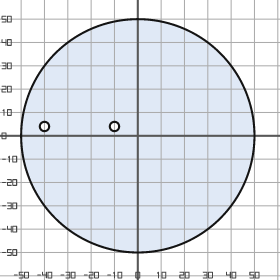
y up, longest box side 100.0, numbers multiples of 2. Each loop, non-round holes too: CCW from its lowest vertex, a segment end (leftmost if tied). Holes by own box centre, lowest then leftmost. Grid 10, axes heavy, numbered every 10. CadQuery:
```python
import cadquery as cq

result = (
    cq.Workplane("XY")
    .moveTo(0.0, 0.0)
    .circle(50.0)
    .moveTo(-40.0, 4.0)
    .circle(2.0)
    .moveTo(-10.0, 4.0)
    .circle(2.0)
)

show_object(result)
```